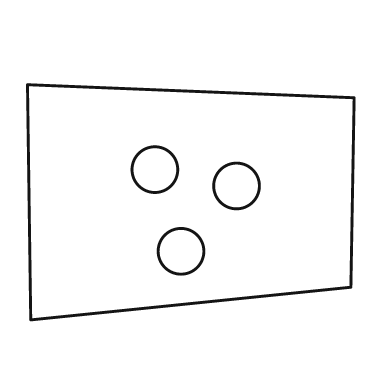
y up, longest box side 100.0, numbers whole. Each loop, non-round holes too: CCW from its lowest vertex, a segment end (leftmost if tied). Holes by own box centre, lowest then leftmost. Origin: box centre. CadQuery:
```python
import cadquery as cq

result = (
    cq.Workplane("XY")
    .moveTo(-49.0, -36.0)
    .lineTo(49.0, -26.0)
    .lineTo(50.0, 32.0)
    .lineTo(-50.0, 36.0)
    .close()
    .moveTo(-3.0, -15.0)
    .circle(7.0)
    .moveTo(14.0, 5.0)
    .circle(7.0)
    .moveTo(-11.0, 10.0)
    .circle(7.0)
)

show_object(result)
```